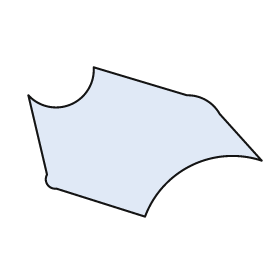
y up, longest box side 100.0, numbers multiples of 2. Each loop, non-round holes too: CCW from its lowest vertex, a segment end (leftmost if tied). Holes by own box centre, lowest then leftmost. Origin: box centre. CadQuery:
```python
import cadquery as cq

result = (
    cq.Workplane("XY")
    .moveTo(0.0, -32.0)
    .threePointArc((20.0, -10.0), (50.0, -8.0))
    .lineTo(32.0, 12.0)
    .threePointArc((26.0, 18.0), (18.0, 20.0))
    .lineTo(-22.0, 32.0)
    .threePointArc((-32.0, 16.0), (-50.0, 20.0))
    .lineTo(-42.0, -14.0)
    .threePointArc((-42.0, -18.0), (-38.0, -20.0))
    .close()
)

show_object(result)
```